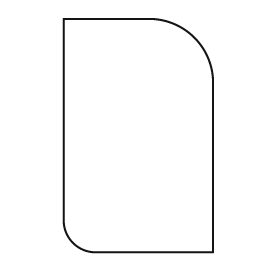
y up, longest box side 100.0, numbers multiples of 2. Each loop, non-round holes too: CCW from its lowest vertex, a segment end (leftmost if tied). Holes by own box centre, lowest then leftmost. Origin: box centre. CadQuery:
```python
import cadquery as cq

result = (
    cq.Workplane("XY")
    .moveTo(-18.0, -50.0)
    .lineTo(32.0, -50.0)
    .lineTo(32.0, 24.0)
    .threePointArc((24.0, 42.0), (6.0, 50.0))
    .lineTo(-32.0, 50.0)
    .lineTo(-32.0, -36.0)
    .threePointArc((-28.0, -46.0), (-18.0, -50.0))
    .close()
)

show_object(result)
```